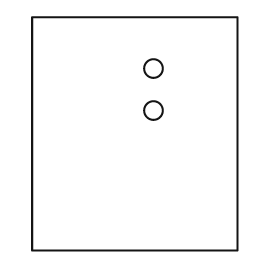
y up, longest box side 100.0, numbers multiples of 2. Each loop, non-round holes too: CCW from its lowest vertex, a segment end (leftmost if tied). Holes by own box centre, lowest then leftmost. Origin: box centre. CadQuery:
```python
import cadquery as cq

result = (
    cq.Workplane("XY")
    .moveTo(-44.0, -50.0)
    .lineTo(44.0, -50.0)
    .lineTo(44.0, 50.0)
    .lineTo(-44.0, 50.0)
    .close()
    .moveTo(8.0, 10.0)
    .circle(4.0)
    .moveTo(8.0, 28.0)
    .circle(4.0)
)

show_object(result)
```